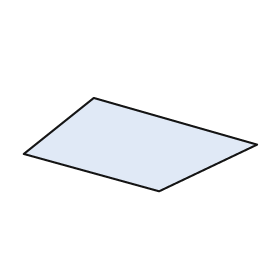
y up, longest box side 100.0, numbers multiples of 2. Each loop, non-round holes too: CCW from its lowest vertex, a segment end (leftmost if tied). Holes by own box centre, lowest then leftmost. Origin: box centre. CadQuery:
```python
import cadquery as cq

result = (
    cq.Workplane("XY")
    .moveTo(8.0, -20.0)
    .lineTo(50.0, 0.0)
    .lineTo(-20.0, 20.0)
    .lineTo(-50.0, -4.0)
    .close()
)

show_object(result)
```